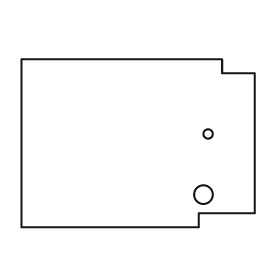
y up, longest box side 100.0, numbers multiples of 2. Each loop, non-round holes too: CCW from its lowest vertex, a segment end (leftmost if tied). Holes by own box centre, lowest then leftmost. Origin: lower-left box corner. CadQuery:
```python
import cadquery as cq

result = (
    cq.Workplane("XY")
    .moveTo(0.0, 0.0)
    .lineTo(76.0, 0.0)
    .lineTo(76.0, 6.0)
    .lineTo(100.0, 6.0)
    .lineTo(100.0, 66.0)
    .lineTo(86.0, 66.0)
    .lineTo(86.0, 72.0)
    .lineTo(0.0, 72.0)
    .close()
    .moveTo(78.0, 14.0)
    .circle(4.0)
    .moveTo(80.0, 40.0)
    .circle(2.0)
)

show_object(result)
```